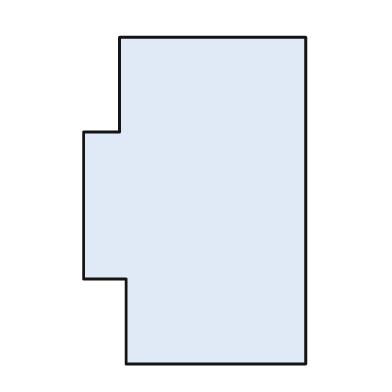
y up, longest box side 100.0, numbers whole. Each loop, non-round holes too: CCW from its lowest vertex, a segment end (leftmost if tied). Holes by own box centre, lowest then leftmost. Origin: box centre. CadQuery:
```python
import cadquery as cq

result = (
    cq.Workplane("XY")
    .moveTo(-21.0, -50.0)
    .lineTo(34.0, -50.0)
    .lineTo(34.0, 50.0)
    .lineTo(-23.0, 50.0)
    .lineTo(-23.0, 21.0)
    .lineTo(-34.0, 21.0)
    .lineTo(-34.0, -24.0)
    .lineTo(-21.0, -24.0)
    .close()
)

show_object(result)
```